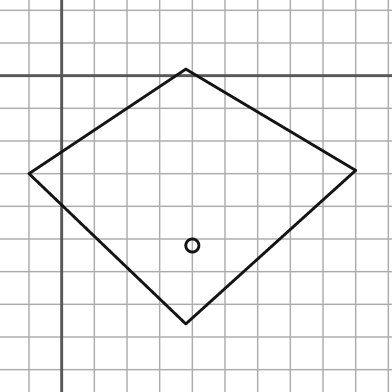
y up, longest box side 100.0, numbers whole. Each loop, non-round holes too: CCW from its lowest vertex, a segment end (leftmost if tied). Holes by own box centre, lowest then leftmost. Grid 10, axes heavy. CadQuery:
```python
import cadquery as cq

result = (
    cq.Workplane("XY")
    .moveTo(38.0, -76.0)
    .lineTo(90.0, -29.0)
    .lineTo(38.0, 2.0)
    .lineTo(-10.0, -30.0)
    .close()
    .moveTo(40.0, -52.0)
    .circle(2.0)
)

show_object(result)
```